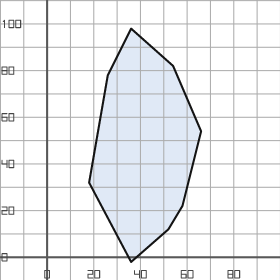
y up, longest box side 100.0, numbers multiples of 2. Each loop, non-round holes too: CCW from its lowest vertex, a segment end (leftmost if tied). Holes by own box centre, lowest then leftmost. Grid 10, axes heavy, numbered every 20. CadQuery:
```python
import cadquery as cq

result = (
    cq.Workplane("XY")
    .moveTo(36.0, -2.0)
    .lineTo(52.0, 12.0)
    .lineTo(58.0, 22.0)
    .lineTo(66.0, 54.0)
    .lineTo(54.0, 82.0)
    .lineTo(36.0, 98.0)
    .lineTo(26.0, 78.0)
    .lineTo(18.0, 32.0)
    .close()
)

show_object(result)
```